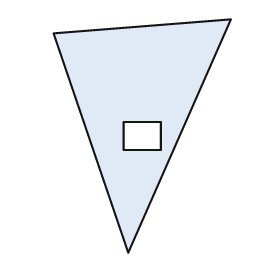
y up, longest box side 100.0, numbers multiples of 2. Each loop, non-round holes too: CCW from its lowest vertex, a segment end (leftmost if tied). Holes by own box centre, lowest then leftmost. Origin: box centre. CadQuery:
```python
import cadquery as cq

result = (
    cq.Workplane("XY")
    .moveTo(-6.0, -50.0)
    .lineTo(38.0, 50.0)
    .lineTo(-38.0, 44.0)
    .close()
    .moveTo(-8.0, -6.0)
    .lineTo(8.0, -6.0)
    .lineTo(8.0, 6.0)
    .lineTo(-8.0, 6.0)
    .close()
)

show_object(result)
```